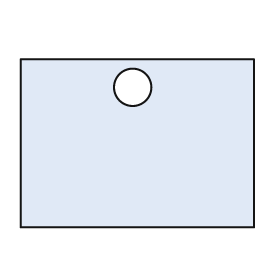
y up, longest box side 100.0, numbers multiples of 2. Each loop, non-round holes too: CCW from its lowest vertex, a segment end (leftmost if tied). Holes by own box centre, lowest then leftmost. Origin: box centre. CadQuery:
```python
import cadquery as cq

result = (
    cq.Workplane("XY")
    .moveTo(-50.0, -36.0)
    .lineTo(50.0, -36.0)
    .lineTo(50.0, 36.0)
    .lineTo(-50.0, 36.0)
    .close()
    .moveTo(-2.0, 24.0)
    .circle(8.0)
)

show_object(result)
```